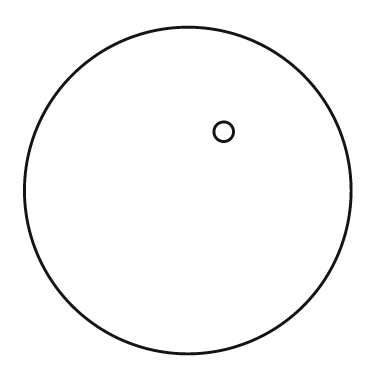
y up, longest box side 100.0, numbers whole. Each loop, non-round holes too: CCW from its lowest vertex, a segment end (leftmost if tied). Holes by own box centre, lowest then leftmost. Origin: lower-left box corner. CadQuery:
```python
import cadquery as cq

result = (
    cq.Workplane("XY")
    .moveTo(50.0, 50.0)
    .circle(50.0)
    .moveTo(61.0, 68.0)
    .circle(3.0)
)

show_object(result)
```